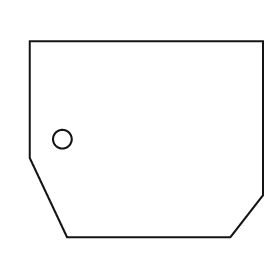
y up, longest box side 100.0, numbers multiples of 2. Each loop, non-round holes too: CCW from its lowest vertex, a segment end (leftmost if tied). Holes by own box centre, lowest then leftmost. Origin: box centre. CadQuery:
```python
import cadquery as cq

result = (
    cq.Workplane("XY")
    .moveTo(-34.0, -42.0)
    .lineTo(36.0, -42.0)
    .lineTo(50.0, -24.0)
    .lineTo(50.0, 42.0)
    .lineTo(-50.0, 42.0)
    .lineTo(-50.0, -8.0)
    .close()
    .moveTo(-36.0, 0.0)
    .circle(4.0)
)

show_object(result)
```